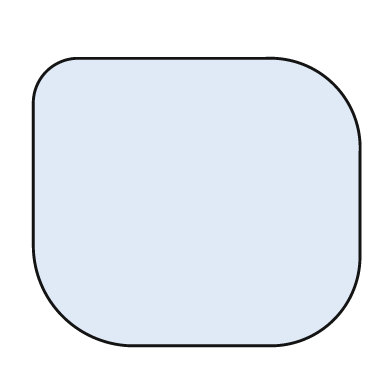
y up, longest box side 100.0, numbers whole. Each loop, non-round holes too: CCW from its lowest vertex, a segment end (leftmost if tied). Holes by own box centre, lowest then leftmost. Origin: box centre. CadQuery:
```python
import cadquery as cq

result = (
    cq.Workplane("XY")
    .moveTo(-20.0, -44.0)
    .lineTo(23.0, -44.0)
    .threePointArc((42.0, -36.0), (50.0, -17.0))
    .lineTo(50.0, 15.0)
    .threePointArc((42.0, 36.0), (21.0, 44.0))
    .lineTo(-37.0, 44.0)
    .threePointArc((-46.0, 40.0), (-50.0, 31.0))
    .lineTo(-50.0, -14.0)
    .threePointArc((-41.0, -35.0), (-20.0, -44.0))
    .close()
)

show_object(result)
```